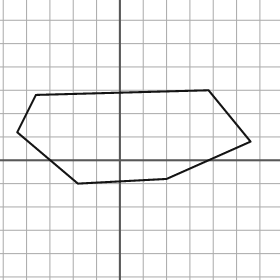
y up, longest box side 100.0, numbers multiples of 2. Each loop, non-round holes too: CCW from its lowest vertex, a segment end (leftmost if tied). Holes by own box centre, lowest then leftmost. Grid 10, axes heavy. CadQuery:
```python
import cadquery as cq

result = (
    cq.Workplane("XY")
    .moveTo(-18.0, -10.0)
    .lineTo(20.0, -8.0)
    .lineTo(56.0, 8.0)
    .lineTo(38.0, 30.0)
    .lineTo(-36.0, 28.0)
    .lineTo(-44.0, 12.0)
    .close()
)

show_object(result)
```